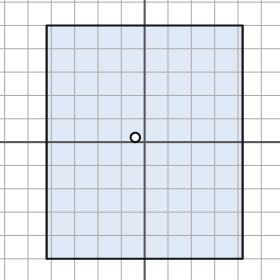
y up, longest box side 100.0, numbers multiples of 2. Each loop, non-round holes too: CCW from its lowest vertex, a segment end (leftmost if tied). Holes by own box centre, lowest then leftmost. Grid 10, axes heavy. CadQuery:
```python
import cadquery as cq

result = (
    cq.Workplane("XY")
    .moveTo(-42.0, -50.0)
    .lineTo(42.0, -50.0)
    .lineTo(42.0, 50.0)
    .lineTo(-42.0, 50.0)
    .close()
    .moveTo(-4.0, 2.0)
    .circle(2.0)
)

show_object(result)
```